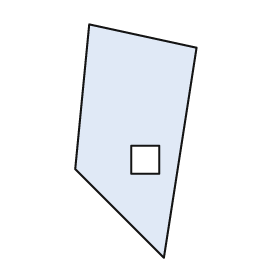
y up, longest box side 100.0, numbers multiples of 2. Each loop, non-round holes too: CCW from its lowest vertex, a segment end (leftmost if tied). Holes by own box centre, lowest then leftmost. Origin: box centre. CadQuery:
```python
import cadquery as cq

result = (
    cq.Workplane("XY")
    .moveTo(12.0, -50.0)
    .lineTo(26.0, 40.0)
    .lineTo(-20.0, 50.0)
    .lineTo(-26.0, -12.0)
    .close()
    .moveTo(-2.0, -14.0)
    .lineTo(10.0, -14.0)
    .lineTo(10.0, -2.0)
    .lineTo(-2.0, -2.0)
    .close()
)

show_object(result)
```